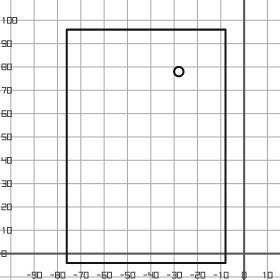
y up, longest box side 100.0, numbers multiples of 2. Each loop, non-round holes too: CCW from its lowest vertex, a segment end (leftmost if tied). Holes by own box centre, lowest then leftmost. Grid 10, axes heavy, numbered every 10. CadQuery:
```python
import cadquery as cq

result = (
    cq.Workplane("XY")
    .moveTo(-76.0, -4.0)
    .lineTo(-8.0, -4.0)
    .lineTo(-8.0, 96.0)
    .lineTo(-76.0, 96.0)
    .close()
    .moveTo(-28.0, 78.0)
    .circle(2.0)
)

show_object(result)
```